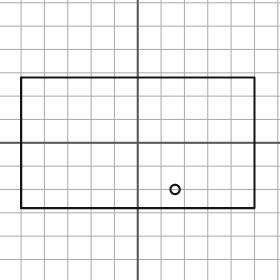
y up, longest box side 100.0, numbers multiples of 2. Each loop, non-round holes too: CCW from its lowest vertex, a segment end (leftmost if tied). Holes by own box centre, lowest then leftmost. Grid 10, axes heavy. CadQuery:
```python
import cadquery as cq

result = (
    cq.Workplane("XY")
    .moveTo(-50.0, -28.0)
    .lineTo(50.0, -28.0)
    .lineTo(50.0, 28.0)
    .lineTo(-50.0, 28.0)
    .close()
    .moveTo(16.0, -20.0)
    .circle(2.0)
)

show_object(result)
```